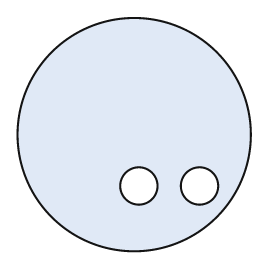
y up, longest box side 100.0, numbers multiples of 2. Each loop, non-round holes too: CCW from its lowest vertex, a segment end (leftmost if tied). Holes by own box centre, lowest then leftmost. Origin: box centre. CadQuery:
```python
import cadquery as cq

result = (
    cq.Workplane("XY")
    .moveTo(0.0, 0.0)
    .circle(50.0)
    .moveTo(2.0, -22.0)
    .circle(8.0)
    .moveTo(28.0, -22.0)
    .circle(8.0)
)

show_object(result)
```